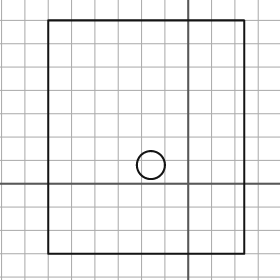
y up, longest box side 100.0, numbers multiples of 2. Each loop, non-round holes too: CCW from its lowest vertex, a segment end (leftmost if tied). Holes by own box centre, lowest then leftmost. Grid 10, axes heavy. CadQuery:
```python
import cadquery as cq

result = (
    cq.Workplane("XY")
    .moveTo(-60.0, -30.0)
    .lineTo(24.0, -30.0)
    .lineTo(24.0, 70.0)
    .lineTo(-60.0, 70.0)
    .close()
    .moveTo(-16.0, 8.0)
    .circle(6.0)
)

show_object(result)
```